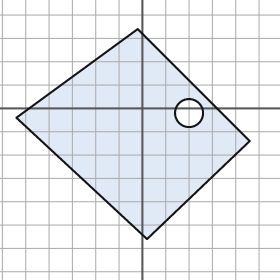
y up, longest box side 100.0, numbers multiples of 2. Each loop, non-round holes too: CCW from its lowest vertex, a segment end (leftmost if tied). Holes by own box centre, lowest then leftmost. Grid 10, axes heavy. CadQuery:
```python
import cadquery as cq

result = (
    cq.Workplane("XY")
    .moveTo(2.0, -56.0)
    .lineTo(46.0, -14.0)
    .lineTo(-2.0, 34.0)
    .lineTo(-54.0, -4.0)
    .close()
    .moveTo(20.0, -2.0)
    .circle(6.0)
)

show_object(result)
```